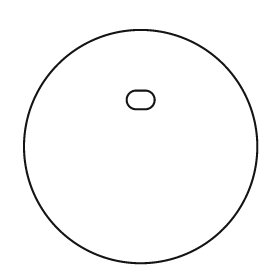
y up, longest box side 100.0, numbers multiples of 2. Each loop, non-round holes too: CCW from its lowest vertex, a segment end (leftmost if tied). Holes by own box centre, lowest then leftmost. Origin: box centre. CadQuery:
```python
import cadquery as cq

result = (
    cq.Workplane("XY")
    .moveTo(0.0, 0.0)
    .circle(50.0)
    .moveTo(-2.0, 16.0)
    .lineTo(2.0, 16.0)
    .threePointArc((6.0, 20.0), (2.0, 24.0))
    .lineTo(-2.0, 24.0)
    .threePointArc((-6.0, 20.0), (-2.0, 16.0))
    .close()
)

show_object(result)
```